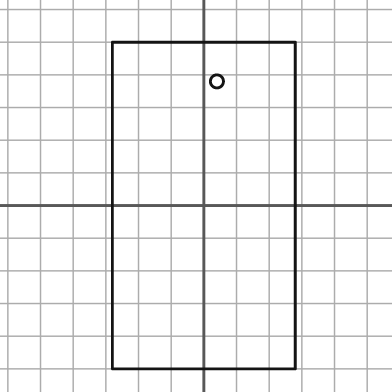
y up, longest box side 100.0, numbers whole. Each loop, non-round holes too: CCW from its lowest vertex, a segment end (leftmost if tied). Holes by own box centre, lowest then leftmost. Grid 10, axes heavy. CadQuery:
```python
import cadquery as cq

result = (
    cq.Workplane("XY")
    .moveTo(-28.0, -50.0)
    .lineTo(28.0, -50.0)
    .lineTo(28.0, 50.0)
    .lineTo(-28.0, 50.0)
    .close()
    .moveTo(4.0, 38.0)
    .circle(2.0)
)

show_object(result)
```